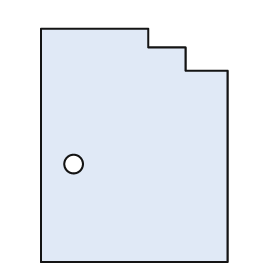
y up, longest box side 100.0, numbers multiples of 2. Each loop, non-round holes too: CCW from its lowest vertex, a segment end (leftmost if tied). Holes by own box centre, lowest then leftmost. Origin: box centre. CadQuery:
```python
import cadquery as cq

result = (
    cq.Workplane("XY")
    .moveTo(-40.0, -50.0)
    .lineTo(40.0, -50.0)
    .lineTo(40.0, 32.0)
    .lineTo(22.0, 32.0)
    .lineTo(22.0, 42.0)
    .lineTo(6.0, 42.0)
    .lineTo(6.0, 50.0)
    .lineTo(-40.0, 50.0)
    .close()
    .moveTo(-26.0, -8.0)
    .circle(4.0)
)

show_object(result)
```